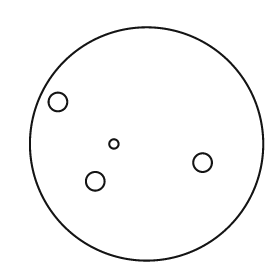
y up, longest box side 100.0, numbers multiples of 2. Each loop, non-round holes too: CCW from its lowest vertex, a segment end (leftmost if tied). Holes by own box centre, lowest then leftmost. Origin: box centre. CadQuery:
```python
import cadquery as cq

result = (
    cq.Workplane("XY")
    .moveTo(0.0, 0.0)
    .circle(50.0)
    .moveTo(-22.0, -16.0)
    .circle(4.0)
    .moveTo(24.0, -8.0)
    .circle(4.0)
    .moveTo(-14.0, 0.0)
    .circle(2.0)
    .moveTo(-38.0, 18.0)
    .circle(4.0)
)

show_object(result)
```